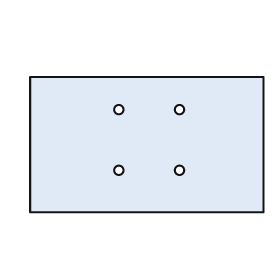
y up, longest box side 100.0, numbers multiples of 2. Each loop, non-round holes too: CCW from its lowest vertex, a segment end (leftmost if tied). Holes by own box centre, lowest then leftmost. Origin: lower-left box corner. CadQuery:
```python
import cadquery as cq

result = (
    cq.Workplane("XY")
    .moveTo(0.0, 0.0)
    .lineTo(100.0, 0.0)
    .lineTo(100.0, 58.0)
    .lineTo(0.0, 58.0)
    .close()
    .moveTo(38.0, 18.0)
    .circle(2.0)
    .moveTo(64.0, 18.0)
    .circle(2.0)
    .moveTo(38.0, 44.0)
    .circle(2.0)
    .moveTo(64.0, 44.0)
    .circle(2.0)
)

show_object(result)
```